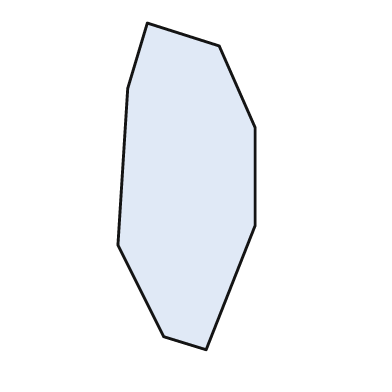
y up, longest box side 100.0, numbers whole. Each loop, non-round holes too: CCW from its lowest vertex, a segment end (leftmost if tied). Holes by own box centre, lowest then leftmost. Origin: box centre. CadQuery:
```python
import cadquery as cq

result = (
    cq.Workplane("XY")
    .moveTo(6.0, -50.0)
    .lineTo(21.0, -12.0)
    .lineTo(21.0, 18.0)
    .lineTo(10.0, 43.0)
    .lineTo(-12.0, 50.0)
    .lineTo(-18.0, 30.0)
    .lineTo(-21.0, -18.0)
    .lineTo(-7.0, -46.0)
    .close()
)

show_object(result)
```